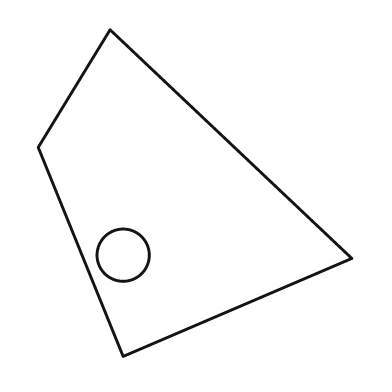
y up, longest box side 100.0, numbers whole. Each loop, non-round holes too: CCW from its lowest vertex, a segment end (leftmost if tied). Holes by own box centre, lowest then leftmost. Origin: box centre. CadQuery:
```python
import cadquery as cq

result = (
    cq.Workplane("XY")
    .moveTo(-22.0, -50.0)
    .lineTo(48.0, -20.0)
    .lineTo(-26.0, 50.0)
    .lineTo(-48.0, 14.0)
    .close()
    .moveTo(-22.0, -19.0)
    .circle(8.0)
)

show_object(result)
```